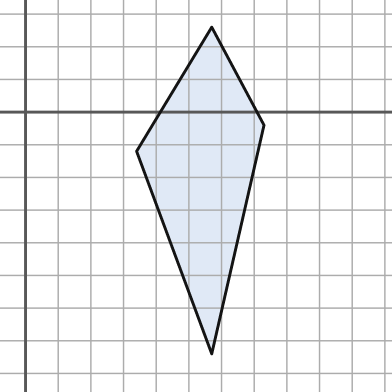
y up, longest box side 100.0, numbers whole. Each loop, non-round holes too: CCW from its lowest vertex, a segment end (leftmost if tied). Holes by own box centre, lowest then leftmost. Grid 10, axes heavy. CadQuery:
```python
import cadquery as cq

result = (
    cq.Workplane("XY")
    .moveTo(57.0, -74.0)
    .lineTo(73.0, -4.0)
    .lineTo(57.0, 26.0)
    .lineTo(34.0, -12.0)
    .close()
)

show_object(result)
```